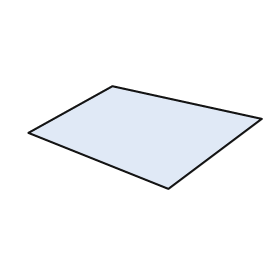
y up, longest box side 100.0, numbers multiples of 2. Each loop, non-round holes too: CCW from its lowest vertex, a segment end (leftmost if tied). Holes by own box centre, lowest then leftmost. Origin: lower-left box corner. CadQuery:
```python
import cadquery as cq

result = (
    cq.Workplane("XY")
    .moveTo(60.0, 0.0)
    .lineTo(100.0, 30.0)
    .lineTo(36.0, 44.0)
    .lineTo(0.0, 24.0)
    .close()
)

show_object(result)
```